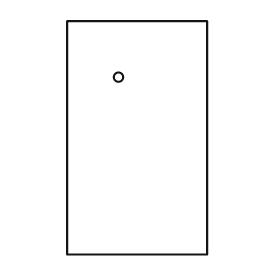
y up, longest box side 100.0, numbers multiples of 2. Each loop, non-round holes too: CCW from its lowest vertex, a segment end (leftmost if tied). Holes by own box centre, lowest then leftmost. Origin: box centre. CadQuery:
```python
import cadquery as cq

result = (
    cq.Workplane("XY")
    .moveTo(-30.0, -50.0)
    .lineTo(30.0, -50.0)
    .lineTo(30.0, 50.0)
    .lineTo(-30.0, 50.0)
    .close()
    .moveTo(-8.0, 26.0)
    .circle(2.0)
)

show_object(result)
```